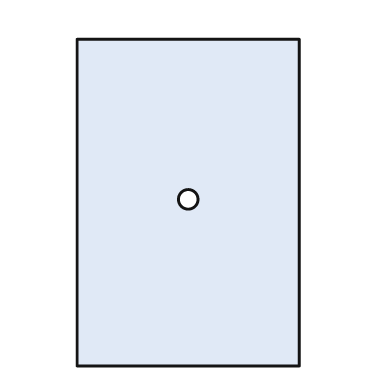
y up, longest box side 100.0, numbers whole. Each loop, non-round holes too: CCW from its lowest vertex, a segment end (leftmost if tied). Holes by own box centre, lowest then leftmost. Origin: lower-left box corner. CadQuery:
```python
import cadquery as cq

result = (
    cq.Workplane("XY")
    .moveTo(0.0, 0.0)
    .lineTo(68.0, 0.0)
    .lineTo(68.0, 100.0)
    .lineTo(0.0, 100.0)
    .close()
    .moveTo(34.0, 51.0)
    .circle(3.0)
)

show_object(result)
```